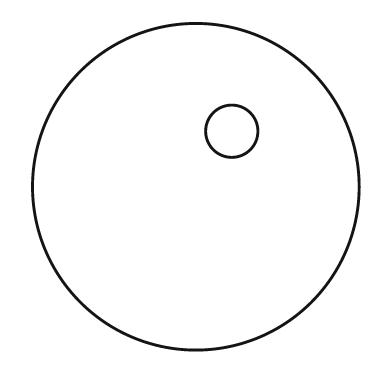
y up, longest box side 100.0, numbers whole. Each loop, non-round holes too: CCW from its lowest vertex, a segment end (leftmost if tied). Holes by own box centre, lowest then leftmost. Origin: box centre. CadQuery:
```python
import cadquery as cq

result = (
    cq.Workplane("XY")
    .moveTo(0.0, 0.0)
    .circle(50.0)
    .moveTo(11.0, 17.0)
    .circle(8.0)
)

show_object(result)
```